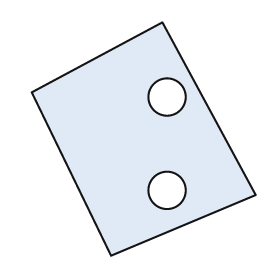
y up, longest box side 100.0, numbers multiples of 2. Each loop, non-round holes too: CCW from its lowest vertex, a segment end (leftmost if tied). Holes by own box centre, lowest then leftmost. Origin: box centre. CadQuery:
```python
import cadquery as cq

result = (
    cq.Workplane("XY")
    .moveTo(-14.0, -50.0)
    .lineTo(48.0, -24.0)
    .lineTo(8.0, 50.0)
    .lineTo(-48.0, 20.0)
    .close()
    .moveTo(10.0, -22.0)
    .circle(8.0)
    .moveTo(10.0, 18.0)
    .circle(8.0)
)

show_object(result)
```